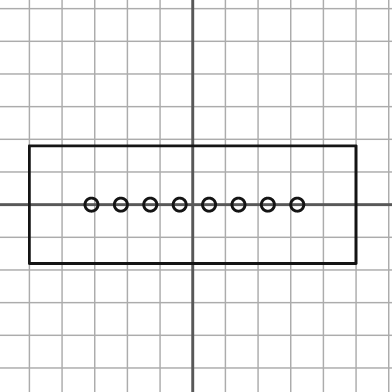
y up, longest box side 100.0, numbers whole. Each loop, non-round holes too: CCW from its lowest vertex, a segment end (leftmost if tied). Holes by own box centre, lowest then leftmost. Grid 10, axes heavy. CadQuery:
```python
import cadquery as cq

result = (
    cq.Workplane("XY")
    .moveTo(-50.0, -18.0)
    .lineTo(50.0, -18.0)
    .lineTo(50.0, 18.0)
    .lineTo(-50.0, 18.0)
    .close()
    .moveTo(-31.0, 0.0)
    .circle(2.0)
    .moveTo(-22.0, 0.0)
    .circle(2.0)
    .moveTo(-13.0, 0.0)
    .circle(2.0)
    .moveTo(-4.0, 0.0)
    .circle(2.0)
    .moveTo(5.0, 0.0)
    .circle(2.0)
    .moveTo(14.0, 0.0)
    .circle(2.0)
    .moveTo(23.0, 0.0)
    .circle(2.0)
    .moveTo(32.0, 0.0)
    .circle(2.0)
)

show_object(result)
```